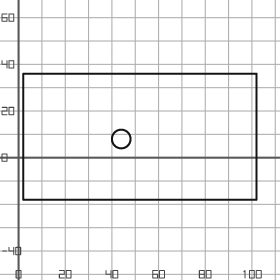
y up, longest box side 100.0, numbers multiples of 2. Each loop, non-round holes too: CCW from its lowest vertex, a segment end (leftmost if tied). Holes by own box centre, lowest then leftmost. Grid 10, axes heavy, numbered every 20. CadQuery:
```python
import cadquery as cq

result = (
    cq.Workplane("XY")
    .moveTo(2.0, -18.0)
    .lineTo(102.0, -18.0)
    .lineTo(102.0, 36.0)
    .lineTo(2.0, 36.0)
    .close()
    .moveTo(44.0, 8.0)
    .circle(4.0)
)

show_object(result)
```